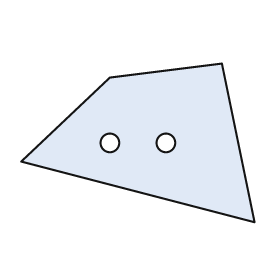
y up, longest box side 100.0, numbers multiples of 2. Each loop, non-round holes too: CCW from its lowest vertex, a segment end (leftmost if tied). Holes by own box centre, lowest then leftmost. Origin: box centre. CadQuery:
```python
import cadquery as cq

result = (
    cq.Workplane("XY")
    .moveTo(50.0, -34.0)
    .lineTo(36.0, 34.0)
    .lineTo(-12.0, 28.0)
    .lineTo(-50.0, -8.0)
    .close()
    .moveTo(-12.0, 0.0)
    .circle(4.0)
    .moveTo(12.0, 0.0)
    .circle(4.0)
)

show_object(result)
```